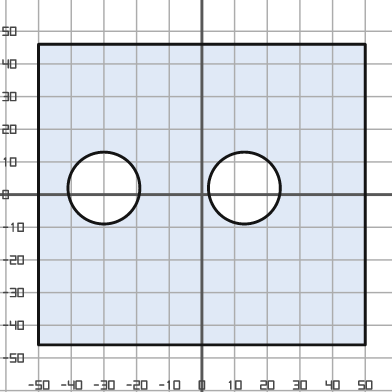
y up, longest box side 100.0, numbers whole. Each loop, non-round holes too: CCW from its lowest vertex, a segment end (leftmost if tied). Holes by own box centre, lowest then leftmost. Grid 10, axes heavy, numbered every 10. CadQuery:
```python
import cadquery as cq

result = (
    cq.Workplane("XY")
    .moveTo(-50.0, -46.0)
    .lineTo(50.0, -46.0)
    .lineTo(50.0, 46.0)
    .lineTo(-50.0, 46.0)
    .close()
    .moveTo(-30.0, 2.0)
    .circle(11.0)
    .moveTo(13.0, 2.0)
    .circle(11.0)
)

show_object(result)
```